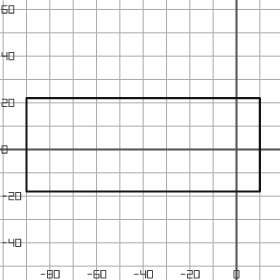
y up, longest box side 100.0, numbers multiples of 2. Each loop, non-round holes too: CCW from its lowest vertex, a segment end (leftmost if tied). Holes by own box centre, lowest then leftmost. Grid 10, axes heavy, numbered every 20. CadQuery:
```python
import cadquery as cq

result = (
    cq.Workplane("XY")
    .moveTo(-90.0, -18.0)
    .lineTo(10.0, -18.0)
    .lineTo(10.0, 22.0)
    .lineTo(-90.0, 22.0)
    .close()
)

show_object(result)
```